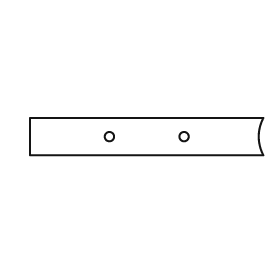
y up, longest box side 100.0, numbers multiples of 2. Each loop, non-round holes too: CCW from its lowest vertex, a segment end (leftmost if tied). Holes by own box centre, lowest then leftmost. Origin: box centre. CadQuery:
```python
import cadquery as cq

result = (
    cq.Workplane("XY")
    .moveTo(-50.0, -8.0)
    .lineTo(50.0, -8.0)
    .threePointArc((48.0, 0.0), (50.0, 8.0))
    .lineTo(-50.0, 8.0)
    .close()
    .moveTo(-16.0, 0.0)
    .circle(2.0)
    .moveTo(16.0, 0.0)
    .circle(2.0)
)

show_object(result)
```